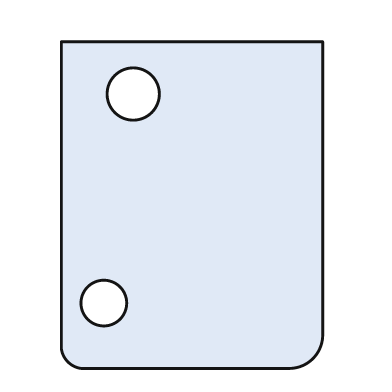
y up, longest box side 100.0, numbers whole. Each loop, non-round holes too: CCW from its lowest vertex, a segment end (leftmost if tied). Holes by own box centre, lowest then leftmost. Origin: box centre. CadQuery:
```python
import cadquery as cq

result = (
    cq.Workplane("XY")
    .moveTo(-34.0, -50.0)
    .lineTo(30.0, -50.0)
    .threePointArc((37.0, -47.0), (40.0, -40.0))
    .lineTo(40.0, 50.0)
    .lineTo(-40.0, 50.0)
    .lineTo(-40.0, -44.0)
    .threePointArc((-38.0, -48.0), (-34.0, -50.0))
    .close()
    .moveTo(-27.0, -30.0)
    .circle(7.0)
    .moveTo(-18.0, 34.0)
    .circle(8.0)
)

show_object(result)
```